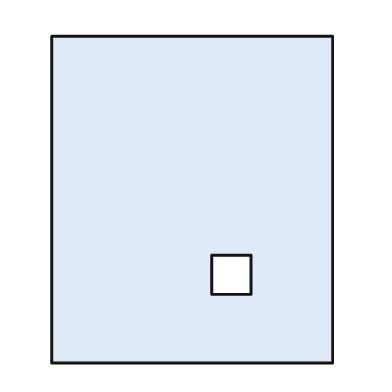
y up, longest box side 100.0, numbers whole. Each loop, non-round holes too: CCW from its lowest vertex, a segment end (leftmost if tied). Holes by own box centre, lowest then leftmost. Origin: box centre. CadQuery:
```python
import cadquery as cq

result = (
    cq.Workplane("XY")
    .moveTo(-43.0, -50.0)
    .lineTo(43.0, -50.0)
    .lineTo(43.0, 50.0)
    .lineTo(-43.0, 50.0)
    .close()
    .moveTo(6.0, -29.0)
    .lineTo(18.0, -29.0)
    .lineTo(18.0, -17.0)
    .lineTo(6.0, -17.0)
    .close()
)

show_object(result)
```